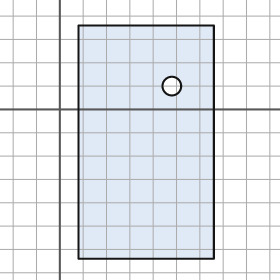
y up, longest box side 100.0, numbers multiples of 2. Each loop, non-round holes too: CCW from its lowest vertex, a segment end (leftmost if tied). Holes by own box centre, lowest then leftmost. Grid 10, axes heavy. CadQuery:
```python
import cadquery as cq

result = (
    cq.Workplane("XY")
    .moveTo(8.0, -64.0)
    .lineTo(66.0, -64.0)
    .lineTo(66.0, 36.0)
    .lineTo(8.0, 36.0)
    .close()
    .moveTo(48.0, 10.0)
    .circle(4.0)
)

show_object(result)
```